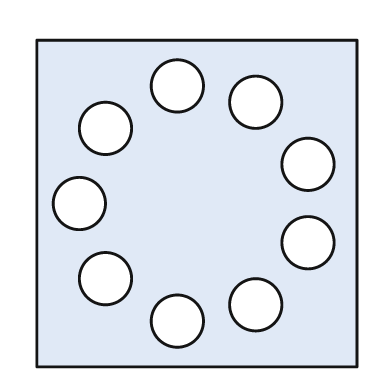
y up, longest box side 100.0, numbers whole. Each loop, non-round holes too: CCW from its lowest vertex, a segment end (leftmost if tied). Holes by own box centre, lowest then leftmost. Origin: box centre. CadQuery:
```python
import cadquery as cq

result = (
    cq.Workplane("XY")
    .moveTo(-49.0, -50.0)
    .lineTo(49.0, -50.0)
    .lineTo(49.0, 50.0)
    .lineTo(-49.0, 50.0)
    .close()
    .moveTo(-6.0, -36.0)
    .circle(8.0)
    .moveTo(18.0, -31.0)
    .circle(8.0)
    .moveTo(-28.0, -23.0)
    .circle(8.0)
    .moveTo(34.0, -12.0)
    .circle(8.0)
    .moveTo(-36.0, 0.0)
    .circle(8.0)
    .moveTo(34.0, 12.0)
    .circle(8.0)
    .moveTo(-28.0, 23.0)
    .circle(8.0)
    .moveTo(18.0, 31.0)
    .circle(8.0)
    .moveTo(-6.0, 36.0)
    .circle(8.0)
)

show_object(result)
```